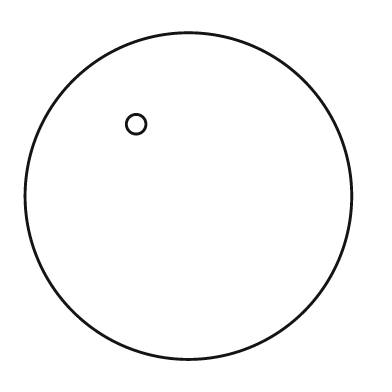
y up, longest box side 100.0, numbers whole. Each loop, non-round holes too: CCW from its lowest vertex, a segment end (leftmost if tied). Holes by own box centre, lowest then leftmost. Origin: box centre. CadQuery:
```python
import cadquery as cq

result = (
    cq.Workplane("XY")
    .moveTo(0.0, 0.0)
    .circle(50.0)
    .moveTo(-16.0, 22.0)
    .circle(3.0)
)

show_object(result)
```